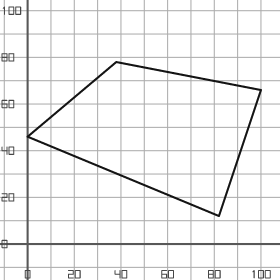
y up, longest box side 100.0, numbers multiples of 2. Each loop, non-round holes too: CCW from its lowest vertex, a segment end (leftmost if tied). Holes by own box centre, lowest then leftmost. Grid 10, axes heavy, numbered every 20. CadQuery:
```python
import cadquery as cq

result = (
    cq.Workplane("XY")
    .moveTo(82.0, 12.0)
    .lineTo(100.0, 66.0)
    .lineTo(38.0, 78.0)
    .lineTo(0.0, 46.0)
    .close()
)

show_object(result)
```